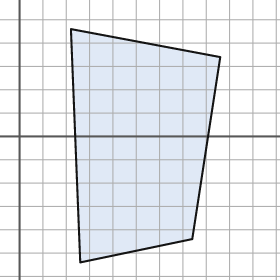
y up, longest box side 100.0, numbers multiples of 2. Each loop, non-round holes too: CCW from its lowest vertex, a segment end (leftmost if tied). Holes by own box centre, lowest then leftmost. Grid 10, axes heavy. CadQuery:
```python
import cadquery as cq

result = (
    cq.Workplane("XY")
    .moveTo(26.0, -54.0)
    .lineTo(74.0, -44.0)
    .lineTo(86.0, 34.0)
    .lineTo(22.0, 46.0)
    .close()
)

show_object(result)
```